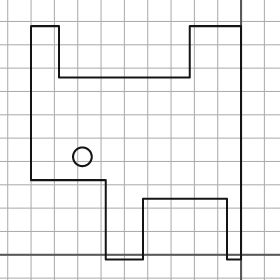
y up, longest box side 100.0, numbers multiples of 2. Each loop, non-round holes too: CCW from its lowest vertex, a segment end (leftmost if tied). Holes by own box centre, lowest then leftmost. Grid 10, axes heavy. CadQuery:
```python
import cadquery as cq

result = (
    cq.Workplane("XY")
    .moveTo(-58.0, -2.0)
    .lineTo(-42.0, -2.0)
    .lineTo(-42.0, 24.0)
    .lineTo(-6.0, 24.0)
    .lineTo(-6.0, -2.0)
    .lineTo(0.0, -2.0)
    .lineTo(0.0, 98.0)
    .lineTo(-22.0, 98.0)
    .lineTo(-22.0, 76.0)
    .lineTo(-78.0, 76.0)
    .lineTo(-78.0, 98.0)
    .lineTo(-90.0, 98.0)
    .lineTo(-90.0, 32.0)
    .lineTo(-58.0, 32.0)
    .close()
    .moveTo(-68.0, 42.0)
    .circle(4.0)
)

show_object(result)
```